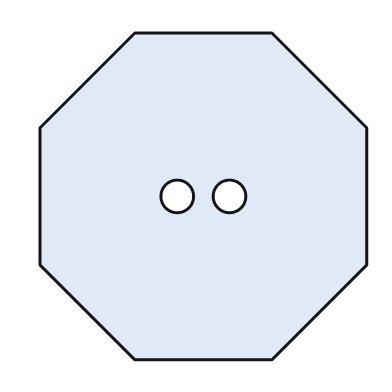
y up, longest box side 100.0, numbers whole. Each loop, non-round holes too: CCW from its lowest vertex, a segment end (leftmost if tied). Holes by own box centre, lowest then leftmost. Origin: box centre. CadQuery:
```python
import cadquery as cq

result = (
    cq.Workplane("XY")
    .moveTo(-21.0, -50.0)
    .lineTo(21.0, -50.0)
    .lineTo(50.0, -21.0)
    .lineTo(50.0, 21.0)
    .lineTo(21.0, 50.0)
    .lineTo(-21.0, 50.0)
    .lineTo(-50.0, 21.0)
    .lineTo(-50.0, -21.0)
    .close()
    .moveTo(-8.0, 0.0)
    .circle(5.0)
    .moveTo(8.0, 0.0)
    .circle(5.0)
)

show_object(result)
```